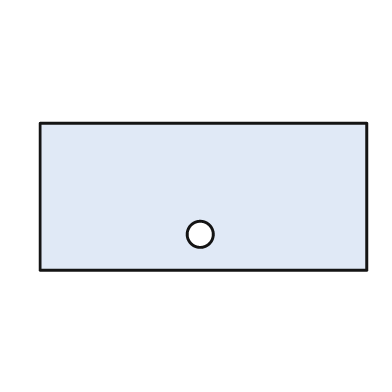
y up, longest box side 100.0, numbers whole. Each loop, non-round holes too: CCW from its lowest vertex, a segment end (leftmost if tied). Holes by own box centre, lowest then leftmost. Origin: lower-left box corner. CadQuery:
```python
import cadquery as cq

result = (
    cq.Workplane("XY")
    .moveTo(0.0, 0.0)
    .lineTo(100.0, 0.0)
    .lineTo(100.0, 45.0)
    .lineTo(0.0, 45.0)
    .close()
    .moveTo(49.0, 11.0)
    .circle(4.0)
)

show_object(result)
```